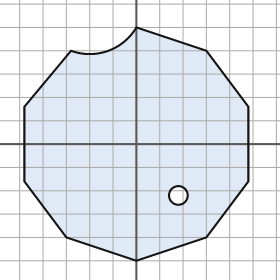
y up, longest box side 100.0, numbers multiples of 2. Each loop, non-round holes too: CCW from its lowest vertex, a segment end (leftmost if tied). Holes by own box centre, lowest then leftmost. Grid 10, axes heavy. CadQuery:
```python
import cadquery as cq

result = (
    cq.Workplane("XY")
    .moveTo(0.0, -50.0)
    .lineTo(30.0, -40.0)
    .lineTo(48.0, -16.0)
    .lineTo(48.0, 16.0)
    .lineTo(30.0, 40.0)
    .lineTo(0.0, 50.0)
    .threePointArc((-12.0, 40.0), (-28.0, 40.0))
    .lineTo(-48.0, 16.0)
    .lineTo(-48.0, -16.0)
    .lineTo(-30.0, -40.0)
    .close()
    .moveTo(18.0, -22.0)
    .circle(4.0)
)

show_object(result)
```